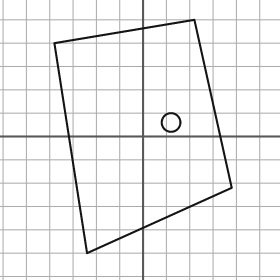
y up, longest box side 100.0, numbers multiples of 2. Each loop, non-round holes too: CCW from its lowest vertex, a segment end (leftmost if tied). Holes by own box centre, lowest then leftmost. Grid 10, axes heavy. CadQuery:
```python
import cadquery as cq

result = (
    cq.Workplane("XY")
    .moveTo(-24.0, -50.0)
    .lineTo(38.0, -22.0)
    .lineTo(22.0, 50.0)
    .lineTo(-38.0, 40.0)
    .close()
    .moveTo(12.0, 6.0)
    .circle(4.0)
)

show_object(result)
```